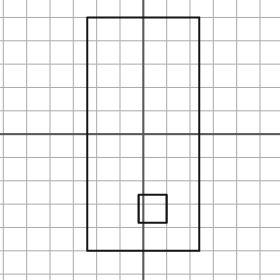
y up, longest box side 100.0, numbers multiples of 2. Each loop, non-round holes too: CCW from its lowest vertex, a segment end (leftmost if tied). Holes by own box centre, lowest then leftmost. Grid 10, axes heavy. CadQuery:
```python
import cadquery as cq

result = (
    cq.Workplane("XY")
    .moveTo(-24.0, -50.0)
    .lineTo(24.0, -50.0)
    .lineTo(24.0, 50.0)
    .lineTo(-24.0, 50.0)
    .close()
    .moveTo(-2.0, -38.0)
    .lineTo(10.0, -38.0)
    .lineTo(10.0, -26.0)
    .lineTo(-2.0, -26.0)
    .close()
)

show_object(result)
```